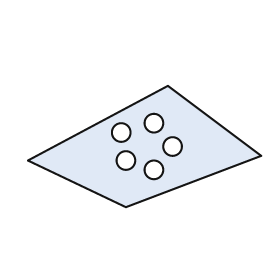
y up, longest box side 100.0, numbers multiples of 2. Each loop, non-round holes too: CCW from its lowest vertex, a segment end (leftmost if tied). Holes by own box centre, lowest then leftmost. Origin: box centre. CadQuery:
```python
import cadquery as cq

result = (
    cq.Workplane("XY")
    .moveTo(-8.0, -26.0)
    .lineTo(50.0, -4.0)
    .lineTo(10.0, 26.0)
    .lineTo(-50.0, -6.0)
    .close()
    .moveTo(4.0, -10.0)
    .circle(4.0)
    .moveTo(-8.0, -6.0)
    .circle(4.0)
    .moveTo(12.0, 0.0)
    .circle(4.0)
    .moveTo(-10.0, 6.0)
    .circle(4.0)
    .moveTo(4.0, 10.0)
    .circle(4.0)
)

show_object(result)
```